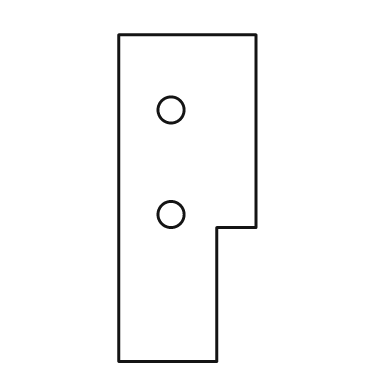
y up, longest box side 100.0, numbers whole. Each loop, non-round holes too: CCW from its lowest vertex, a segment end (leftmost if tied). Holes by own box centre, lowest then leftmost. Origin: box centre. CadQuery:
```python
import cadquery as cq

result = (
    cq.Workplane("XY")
    .moveTo(-21.0, -50.0)
    .lineTo(9.0, -50.0)
    .lineTo(9.0, -9.0)
    .lineTo(21.0, -9.0)
    .lineTo(21.0, 50.0)
    .lineTo(-21.0, 50.0)
    .close()
    .moveTo(-5.0, -5.0)
    .circle(4.0)
    .moveTo(-5.0, 27.0)
    .circle(4.0)
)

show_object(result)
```